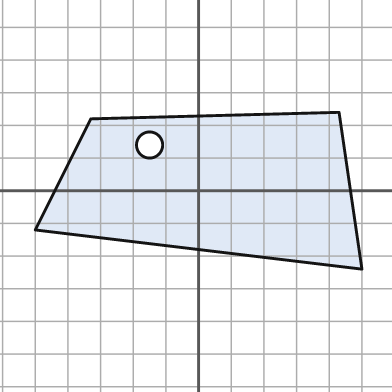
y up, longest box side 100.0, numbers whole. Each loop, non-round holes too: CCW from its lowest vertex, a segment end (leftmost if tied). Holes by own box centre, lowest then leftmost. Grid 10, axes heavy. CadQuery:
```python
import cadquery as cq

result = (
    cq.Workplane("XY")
    .moveTo(50.0, -24.0)
    .lineTo(43.0, 24.0)
    .lineTo(-33.0, 22.0)
    .lineTo(-50.0, -12.0)
    .close()
    .moveTo(-15.0, 14.0)
    .circle(4.0)
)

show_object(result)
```